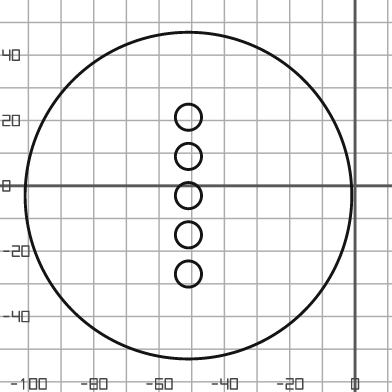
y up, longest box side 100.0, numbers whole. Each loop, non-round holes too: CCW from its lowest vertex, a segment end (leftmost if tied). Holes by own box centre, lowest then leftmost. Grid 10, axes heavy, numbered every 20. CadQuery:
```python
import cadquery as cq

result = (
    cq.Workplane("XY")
    .moveTo(-51.0, -3.0)
    .circle(50.0)
    .moveTo(-51.0, -27.0)
    .circle(4.0)
    .moveTo(-51.0, -15.0)
    .circle(4.0)
    .moveTo(-51.0, -3.0)
    .circle(4.0)
    .moveTo(-51.0, 9.0)
    .circle(4.0)
    .moveTo(-51.0, 21.0)
    .circle(4.0)
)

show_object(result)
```